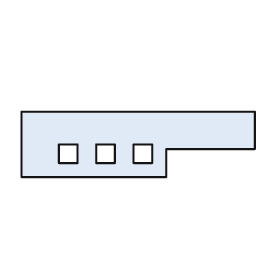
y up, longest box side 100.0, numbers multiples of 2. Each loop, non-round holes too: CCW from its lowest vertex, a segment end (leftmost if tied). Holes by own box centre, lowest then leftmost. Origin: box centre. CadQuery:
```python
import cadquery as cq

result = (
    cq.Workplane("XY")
    .moveTo(-50.0, -14.0)
    .lineTo(12.0, -14.0)
    .lineTo(12.0, -2.0)
    .lineTo(50.0, -2.0)
    .lineTo(50.0, 14.0)
    .lineTo(-50.0, 14.0)
    .close()
    .moveTo(-34.0, -8.0)
    .lineTo(-26.0, -8.0)
    .lineTo(-26.0, 0.0)
    .lineTo(-34.0, 0.0)
    .close()
    .moveTo(-18.0, -8.0)
    .lineTo(-10.0, -8.0)
    .lineTo(-10.0, 0.0)
    .lineTo(-18.0, 0.0)
    .close()
    .moveTo(-2.0, -8.0)
    .lineTo(6.0, -8.0)
    .lineTo(6.0, 0.0)
    .lineTo(-2.0, 0.0)
    .close()
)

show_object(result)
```